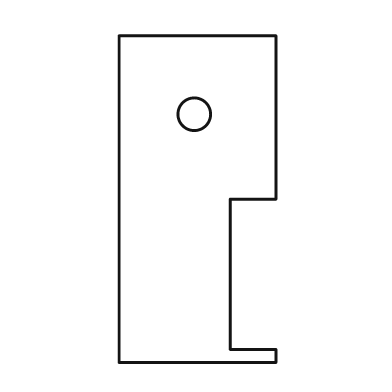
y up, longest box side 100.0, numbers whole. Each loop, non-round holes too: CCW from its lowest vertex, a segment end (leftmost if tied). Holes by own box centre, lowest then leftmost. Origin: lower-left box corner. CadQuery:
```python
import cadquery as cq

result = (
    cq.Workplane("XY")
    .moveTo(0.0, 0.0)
    .lineTo(48.0, 0.0)
    .lineTo(48.0, 4.0)
    .lineTo(34.0, 4.0)
    .lineTo(34.0, 50.0)
    .lineTo(48.0, 50.0)
    .lineTo(48.0, 100.0)
    .lineTo(0.0, 100.0)
    .close()
    .moveTo(23.0, 76.0)
    .circle(5.0)
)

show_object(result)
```